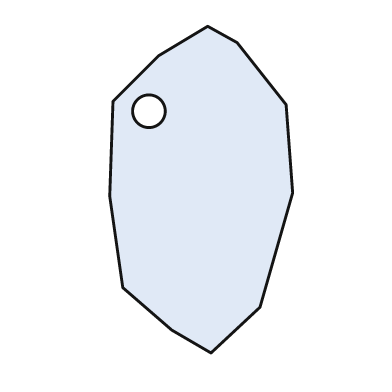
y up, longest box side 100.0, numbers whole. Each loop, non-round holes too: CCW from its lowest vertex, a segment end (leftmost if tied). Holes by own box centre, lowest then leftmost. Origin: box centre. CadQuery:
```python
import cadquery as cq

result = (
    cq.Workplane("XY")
    .moveTo(3.0, -50.0)
    .lineTo(18.0, -36.0)
    .lineTo(28.0, -1.0)
    .lineTo(26.0, 26.0)
    .lineTo(11.0, 45.0)
    .lineTo(2.0, 50.0)
    .lineTo(-13.0, 41.0)
    .lineTo(-27.0, 27.0)
    .lineTo(-28.0, -2.0)
    .lineTo(-24.0, -30.0)
    .lineTo(-9.0, -43.0)
    .close()
    .moveTo(-16.0, 24.0)
    .circle(5.0)
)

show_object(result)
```